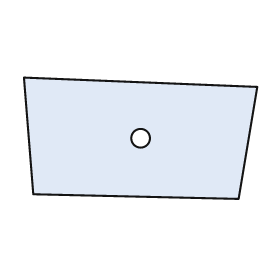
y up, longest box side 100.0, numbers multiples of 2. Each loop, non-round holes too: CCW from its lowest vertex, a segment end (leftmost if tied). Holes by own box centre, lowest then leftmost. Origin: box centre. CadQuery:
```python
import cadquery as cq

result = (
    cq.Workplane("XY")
    .moveTo(42.0, -26.0)
    .lineTo(50.0, 22.0)
    .lineTo(-50.0, 26.0)
    .lineTo(-46.0, -24.0)
    .close()
    .moveTo(0.0, 0.0)
    .circle(4.0)
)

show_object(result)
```